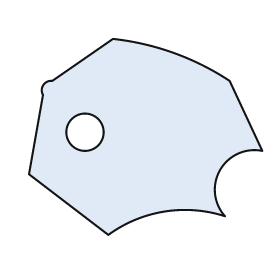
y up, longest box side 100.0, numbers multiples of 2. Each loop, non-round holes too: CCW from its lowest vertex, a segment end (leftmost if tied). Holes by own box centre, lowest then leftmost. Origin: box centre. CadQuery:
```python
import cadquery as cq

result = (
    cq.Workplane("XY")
    .moveTo(-16.0, -42.0)
    .threePointArc((8.0, -32.0), (34.0, -34.0))
    .threePointArc((32.0, -14.0), (50.0, -6.0))
    .lineTo(36.0, 24.0)
    .threePointArc((12.0, 36.0), (-14.0, 42.0))
    .lineTo(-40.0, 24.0)
    .threePointArc((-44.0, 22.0), (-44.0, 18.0))
    .lineTo(-50.0, -16.0)
    .close()
    .moveTo(-26.0, 2.0)
    .circle(8.0)
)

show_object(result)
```